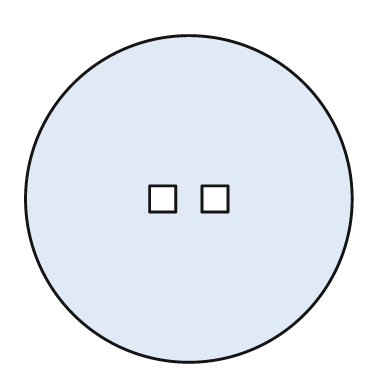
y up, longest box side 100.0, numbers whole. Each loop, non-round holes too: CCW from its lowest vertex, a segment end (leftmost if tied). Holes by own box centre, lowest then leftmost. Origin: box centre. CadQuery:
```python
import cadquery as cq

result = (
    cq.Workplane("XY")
    .moveTo(0.0, 0.0)
    .circle(50.0)
    .moveTo(-12.0, -4.0)
    .lineTo(-4.0, -4.0)
    .lineTo(-4.0, 4.0)
    .lineTo(-12.0, 4.0)
    .close()
    .moveTo(4.0, -4.0)
    .lineTo(12.0, -4.0)
    .lineTo(12.0, 4.0)
    .lineTo(4.0, 4.0)
    .close()
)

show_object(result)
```